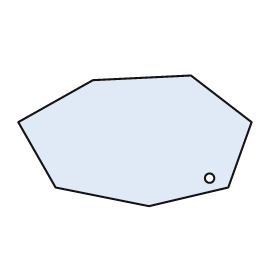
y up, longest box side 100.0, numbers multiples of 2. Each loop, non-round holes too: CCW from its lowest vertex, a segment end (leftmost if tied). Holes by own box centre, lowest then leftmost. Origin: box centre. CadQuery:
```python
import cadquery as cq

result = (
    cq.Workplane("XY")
    .moveTo(6.0, -28.0)
    .lineTo(40.0, -20.0)
    .lineTo(50.0, 8.0)
    .lineTo(24.0, 28.0)
    .lineTo(-18.0, 26.0)
    .lineTo(-50.0, 8.0)
    .lineTo(-34.0, -20.0)
    .close()
    .moveTo(32.0, -16.0)
    .circle(2.0)
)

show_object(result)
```